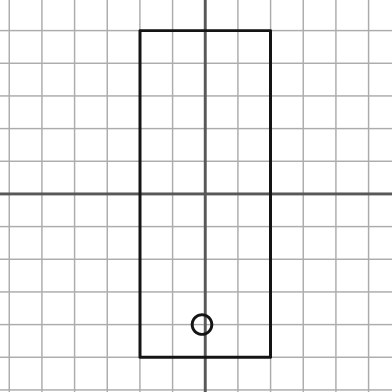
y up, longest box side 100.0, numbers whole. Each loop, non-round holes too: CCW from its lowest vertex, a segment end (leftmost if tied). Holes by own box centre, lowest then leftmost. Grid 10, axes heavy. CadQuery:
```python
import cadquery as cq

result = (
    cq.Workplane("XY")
    .moveTo(-20.0, -50.0)
    .lineTo(20.0, -50.0)
    .lineTo(20.0, 50.0)
    .lineTo(-20.0, 50.0)
    .close()
    .moveTo(-1.0, -40.0)
    .circle(3.0)
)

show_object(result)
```